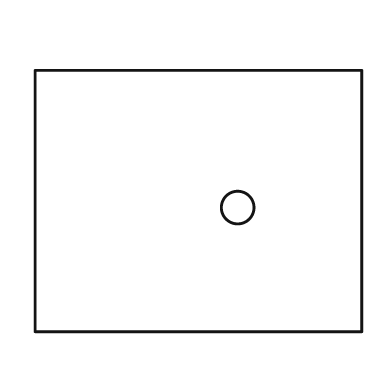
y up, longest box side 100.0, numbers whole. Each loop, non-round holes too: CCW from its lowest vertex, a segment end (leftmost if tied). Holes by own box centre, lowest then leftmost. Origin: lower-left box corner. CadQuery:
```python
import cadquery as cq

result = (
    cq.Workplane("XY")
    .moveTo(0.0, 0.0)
    .lineTo(100.0, 0.0)
    .lineTo(100.0, 80.0)
    .lineTo(0.0, 80.0)
    .close()
    .moveTo(62.0, 38.0)
    .circle(5.0)
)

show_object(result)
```